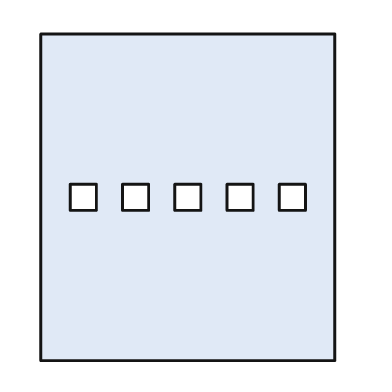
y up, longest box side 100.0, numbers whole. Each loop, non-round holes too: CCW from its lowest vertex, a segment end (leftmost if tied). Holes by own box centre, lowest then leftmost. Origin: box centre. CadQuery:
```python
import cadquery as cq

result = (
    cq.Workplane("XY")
    .moveTo(-45.0, -50.0)
    .lineTo(45.0, -50.0)
    .lineTo(45.0, 50.0)
    .lineTo(-45.0, 50.0)
    .close()
    .moveTo(-36.0, -4.0)
    .lineTo(-28.0, -4.0)
    .lineTo(-28.0, 4.0)
    .lineTo(-36.0, 4.0)
    .close()
    .moveTo(-20.0, -4.0)
    .lineTo(-12.0, -4.0)
    .lineTo(-12.0, 4.0)
    .lineTo(-20.0, 4.0)
    .close()
    .moveTo(-4.0, -4.0)
    .lineTo(4.0, -4.0)
    .lineTo(4.0, 4.0)
    .lineTo(-4.0, 4.0)
    .close()
    .moveTo(12.0, -4.0)
    .lineTo(20.0, -4.0)
    .lineTo(20.0, 4.0)
    .lineTo(12.0, 4.0)
    .close()
    .moveTo(28.0, -4.0)
    .lineTo(36.0, -4.0)
    .lineTo(36.0, 4.0)
    .lineTo(28.0, 4.0)
    .close()
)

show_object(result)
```